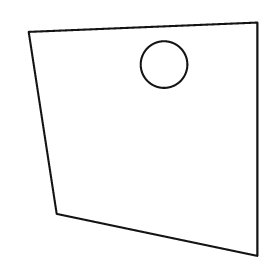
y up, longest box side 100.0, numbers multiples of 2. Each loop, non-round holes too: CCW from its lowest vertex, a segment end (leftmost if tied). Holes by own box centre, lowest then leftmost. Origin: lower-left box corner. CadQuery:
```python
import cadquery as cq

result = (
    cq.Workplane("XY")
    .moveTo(98.0, 0.0)
    .lineTo(98.0, 100.0)
    .lineTo(0.0, 96.0)
    .lineTo(12.0, 18.0)
    .close()
    .moveTo(58.0, 82.0)
    .circle(10.0)
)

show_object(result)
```